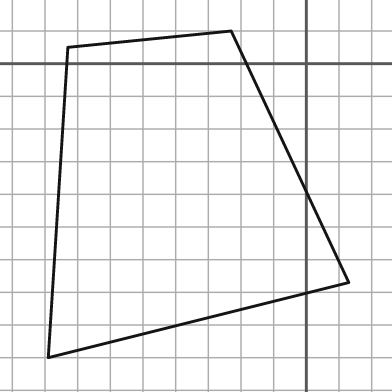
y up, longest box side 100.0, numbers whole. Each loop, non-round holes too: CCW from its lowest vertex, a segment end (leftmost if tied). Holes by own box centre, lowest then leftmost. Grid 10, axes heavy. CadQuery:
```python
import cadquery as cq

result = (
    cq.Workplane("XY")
    .moveTo(-79.0, -90.0)
    .lineTo(13.0, -67.0)
    .lineTo(-23.0, 10.0)
    .lineTo(-73.0, 5.0)
    .close()
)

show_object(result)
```